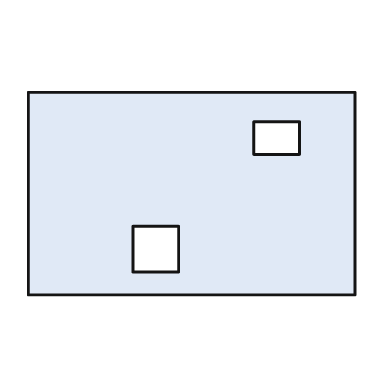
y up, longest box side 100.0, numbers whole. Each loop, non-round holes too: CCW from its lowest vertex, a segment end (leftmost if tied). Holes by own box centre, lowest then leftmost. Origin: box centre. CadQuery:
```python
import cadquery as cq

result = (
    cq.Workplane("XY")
    .moveTo(-50.0, -31.0)
    .lineTo(50.0, -31.0)
    .lineTo(50.0, 31.0)
    .lineTo(-50.0, 31.0)
    .close()
    .moveTo(-18.0, -24.0)
    .lineTo(-4.0, -24.0)
    .lineTo(-4.0, -10.0)
    .lineTo(-18.0, -10.0)
    .close()
    .moveTo(19.0, 12.0)
    .lineTo(33.0, 12.0)
    .lineTo(33.0, 22.0)
    .lineTo(19.0, 22.0)
    .close()
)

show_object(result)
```